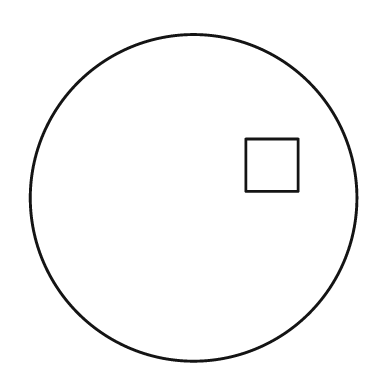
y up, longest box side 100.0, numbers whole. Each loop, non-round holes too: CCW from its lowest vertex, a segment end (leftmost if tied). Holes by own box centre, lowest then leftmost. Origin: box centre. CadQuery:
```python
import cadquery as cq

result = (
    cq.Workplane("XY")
    .moveTo(0.0, 0.0)
    .circle(50.0)
    .moveTo(16.0, 2.0)
    .lineTo(32.0, 2.0)
    .lineTo(32.0, 18.0)
    .lineTo(16.0, 18.0)
    .close()
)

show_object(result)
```